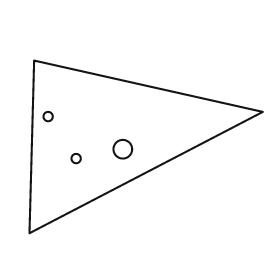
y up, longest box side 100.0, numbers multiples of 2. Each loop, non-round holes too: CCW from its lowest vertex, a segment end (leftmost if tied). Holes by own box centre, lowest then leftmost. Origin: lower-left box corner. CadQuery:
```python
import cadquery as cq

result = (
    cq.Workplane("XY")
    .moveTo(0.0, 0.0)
    .lineTo(100.0, 52.0)
    .lineTo(2.0, 74.0)
    .close()
    .moveTo(20.0, 32.0)
    .circle(2.0)
    .moveTo(40.0, 36.0)
    .circle(4.0)
    .moveTo(8.0, 50.0)
    .circle(2.0)
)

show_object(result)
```